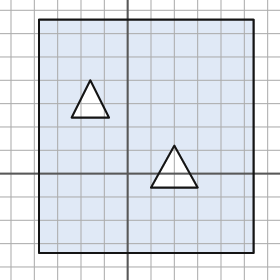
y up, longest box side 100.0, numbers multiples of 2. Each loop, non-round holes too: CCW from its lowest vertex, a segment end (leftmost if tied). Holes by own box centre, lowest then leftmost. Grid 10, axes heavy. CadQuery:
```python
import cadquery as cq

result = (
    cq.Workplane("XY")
    .moveTo(-38.0, -34.0)
    .lineTo(54.0, -34.0)
    .lineTo(54.0, 66.0)
    .lineTo(-38.0, 66.0)
    .close()
    .moveTo(10.0, -6.0)
    .lineTo(30.0, -6.0)
    .lineTo(20.0, 12.0)
    .close()
    .moveTo(-24.0, 24.0)
    .lineTo(-8.0, 24.0)
    .lineTo(-16.0, 40.0)
    .close()
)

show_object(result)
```